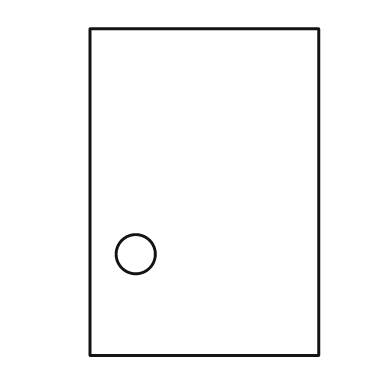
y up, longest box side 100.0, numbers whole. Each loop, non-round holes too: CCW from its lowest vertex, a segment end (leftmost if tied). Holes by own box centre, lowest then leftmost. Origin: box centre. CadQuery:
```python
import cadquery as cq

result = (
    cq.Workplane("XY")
    .moveTo(-35.0, -50.0)
    .lineTo(35.0, -50.0)
    .lineTo(35.0, 50.0)
    .lineTo(-35.0, 50.0)
    .close()
    .moveTo(-21.0, -19.0)
    .circle(6.0)
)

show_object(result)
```